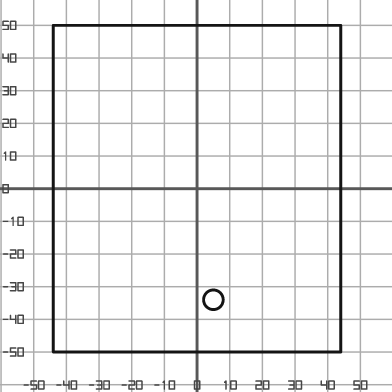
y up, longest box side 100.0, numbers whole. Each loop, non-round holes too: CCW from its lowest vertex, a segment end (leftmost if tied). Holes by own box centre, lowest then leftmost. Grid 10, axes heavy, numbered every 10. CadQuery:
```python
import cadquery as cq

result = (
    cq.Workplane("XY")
    .moveTo(-44.0, -50.0)
    .lineTo(44.0, -50.0)
    .lineTo(44.0, 50.0)
    .lineTo(-44.0, 50.0)
    .close()
    .moveTo(5.0, -34.0)
    .circle(3.0)
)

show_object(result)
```